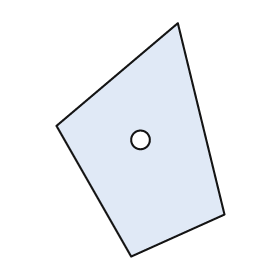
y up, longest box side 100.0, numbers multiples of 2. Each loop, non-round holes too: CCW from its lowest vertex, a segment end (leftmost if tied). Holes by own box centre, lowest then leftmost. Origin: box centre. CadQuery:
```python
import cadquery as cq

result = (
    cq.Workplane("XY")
    .moveTo(-4.0, -50.0)
    .lineTo(36.0, -32.0)
    .lineTo(16.0, 50.0)
    .lineTo(-36.0, 6.0)
    .close()
    .moveTo(0.0, 0.0)
    .circle(4.0)
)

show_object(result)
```